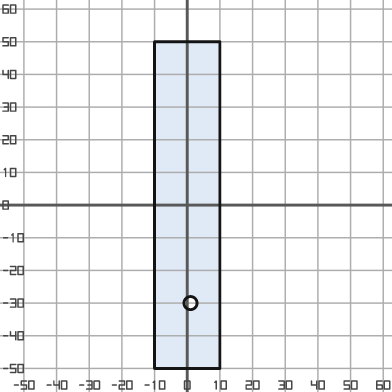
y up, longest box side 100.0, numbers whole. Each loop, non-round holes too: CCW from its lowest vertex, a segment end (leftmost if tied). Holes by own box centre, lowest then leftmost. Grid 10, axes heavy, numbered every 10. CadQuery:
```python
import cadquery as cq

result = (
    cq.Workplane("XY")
    .moveTo(-10.0, -50.0)
    .lineTo(10.0, -50.0)
    .lineTo(10.0, 50.0)
    .lineTo(-10.0, 50.0)
    .close()
    .moveTo(1.0, -30.0)
    .circle(2.0)
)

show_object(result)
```